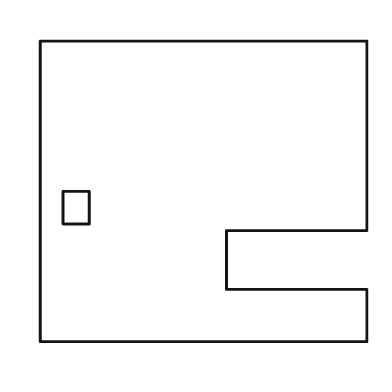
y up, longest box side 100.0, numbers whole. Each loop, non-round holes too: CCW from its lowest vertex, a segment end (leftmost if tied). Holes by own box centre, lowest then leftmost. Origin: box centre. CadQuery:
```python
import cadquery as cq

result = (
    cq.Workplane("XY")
    .moveTo(-50.0, -46.0)
    .lineTo(50.0, -46.0)
    .lineTo(50.0, -30.0)
    .lineTo(7.0, -30.0)
    .lineTo(7.0, -12.0)
    .lineTo(50.0, -12.0)
    .lineTo(50.0, 46.0)
    .lineTo(-50.0, 46.0)
    .close()
    .moveTo(-43.0, -10.0)
    .lineTo(-35.0, -10.0)
    .lineTo(-35.0, 0.0)
    .lineTo(-43.0, 0.0)
    .close()
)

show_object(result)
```